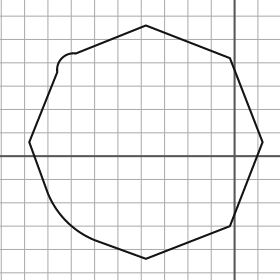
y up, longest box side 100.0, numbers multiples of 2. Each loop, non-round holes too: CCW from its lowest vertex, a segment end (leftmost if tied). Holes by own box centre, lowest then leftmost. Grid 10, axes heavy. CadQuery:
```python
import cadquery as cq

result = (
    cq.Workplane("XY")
    .moveTo(-38.0, -44.0)
    .lineTo(-2.0, -30.0)
    .lineTo(12.0, 6.0)
    .lineTo(-2.0, 42.0)
    .lineTo(-38.0, 56.0)
    .lineTo(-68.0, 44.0)
    .threePointArc((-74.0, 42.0), (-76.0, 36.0))
    .lineTo(-88.0, 6.0)
    .lineTo(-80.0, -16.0)
    .threePointArc((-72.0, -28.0), (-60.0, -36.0))
    .close()
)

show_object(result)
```